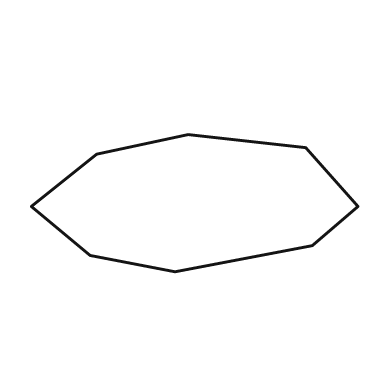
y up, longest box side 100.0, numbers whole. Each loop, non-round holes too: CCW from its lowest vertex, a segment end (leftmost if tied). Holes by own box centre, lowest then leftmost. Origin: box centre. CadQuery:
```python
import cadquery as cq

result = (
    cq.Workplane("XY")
    .moveTo(-6.0, -21.0)
    .lineTo(36.0, -13.0)
    .lineTo(50.0, -1.0)
    .lineTo(34.0, 17.0)
    .lineTo(-2.0, 21.0)
    .lineTo(-30.0, 15.0)
    .lineTo(-50.0, -1.0)
    .lineTo(-32.0, -16.0)
    .close()
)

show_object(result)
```